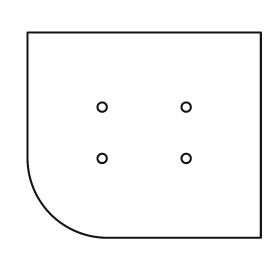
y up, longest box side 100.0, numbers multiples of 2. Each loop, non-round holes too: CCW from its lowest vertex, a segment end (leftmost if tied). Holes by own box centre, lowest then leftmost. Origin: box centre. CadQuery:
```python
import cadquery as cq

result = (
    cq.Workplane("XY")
    .moveTo(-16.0, -44.0)
    .lineTo(50.0, -44.0)
    .lineTo(50.0, 44.0)
    .lineTo(-50.0, 44.0)
    .lineTo(-50.0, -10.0)
    .threePointArc((-40.0, -34.0), (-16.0, -44.0))
    .close()
    .moveTo(-18.0, -10.0)
    .circle(2.0)
    .moveTo(18.0, -10.0)
    .circle(2.0)
    .moveTo(-18.0, 12.0)
    .circle(2.0)
    .moveTo(18.0, 12.0)
    .circle(2.0)
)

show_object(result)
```